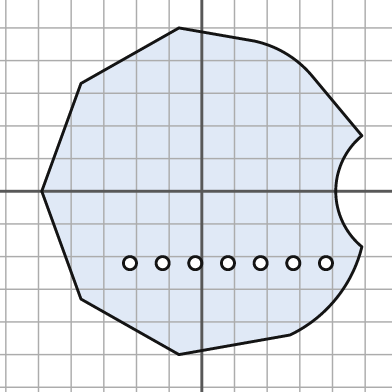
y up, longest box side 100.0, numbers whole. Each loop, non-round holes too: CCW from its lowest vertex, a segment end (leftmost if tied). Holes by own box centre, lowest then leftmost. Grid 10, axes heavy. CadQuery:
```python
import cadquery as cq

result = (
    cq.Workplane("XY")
    .moveTo(-7.0, -50.0)
    .lineTo(27.0, -44.0)
    .threePointArc((41.0, -33.0), (49.0, -17.0))
    .threePointArc((41.0, 0.0), (49.0, 17.0))
    .lineTo(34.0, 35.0)
    .threePointArc((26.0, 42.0), (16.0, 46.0))
    .lineTo(-7.0, 50.0)
    .lineTo(-37.0, 33.0)
    .lineTo(-49.0, 0.0)
    .lineTo(-37.0, -33.0)
    .close()
    .moveTo(-22.0, -22.0)
    .circle(2.0)
    .moveTo(-12.0, -22.0)
    .circle(2.0)
    .moveTo(-2.0, -22.0)
    .circle(2.0)
    .moveTo(8.0, -22.0)
    .circle(2.0)
    .moveTo(18.0, -22.0)
    .circle(2.0)
    .moveTo(28.0, -22.0)
    .circle(2.0)
    .moveTo(38.0, -22.0)
    .circle(2.0)
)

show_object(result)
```